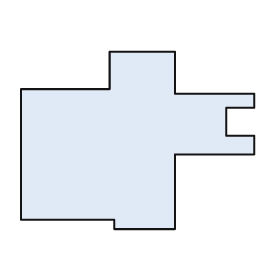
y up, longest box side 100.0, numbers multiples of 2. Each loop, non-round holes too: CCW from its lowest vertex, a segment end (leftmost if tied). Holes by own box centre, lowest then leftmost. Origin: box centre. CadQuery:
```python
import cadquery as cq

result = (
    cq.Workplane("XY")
    .moveTo(-10.0, -38.0)
    .lineTo(16.0, -38.0)
    .lineTo(16.0, -6.0)
    .lineTo(50.0, -6.0)
    .lineTo(50.0, 2.0)
    .lineTo(38.0, 2.0)
    .lineTo(38.0, 14.0)
    .lineTo(50.0, 14.0)
    .lineTo(50.0, 20.0)
    .lineTo(16.0, 20.0)
    .lineTo(16.0, 38.0)
    .lineTo(-12.0, 38.0)
    .lineTo(-12.0, 22.0)
    .lineTo(-50.0, 22.0)
    .lineTo(-50.0, -34.0)
    .lineTo(-10.0, -34.0)
    .close()
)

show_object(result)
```